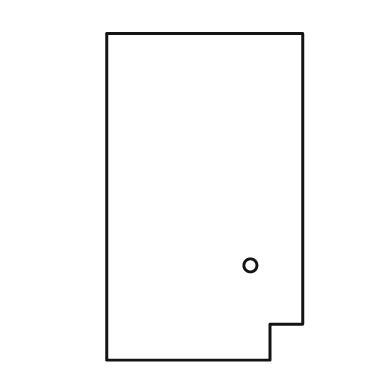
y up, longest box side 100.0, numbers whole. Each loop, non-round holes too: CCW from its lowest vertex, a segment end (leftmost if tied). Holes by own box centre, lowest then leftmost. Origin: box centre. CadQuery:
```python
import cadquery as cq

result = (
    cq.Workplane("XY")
    .moveTo(-30.0, -50.0)
    .lineTo(20.0, -50.0)
    .lineTo(20.0, -39.0)
    .lineTo(30.0, -39.0)
    .lineTo(30.0, 50.0)
    .lineTo(-30.0, 50.0)
    .close()
    .moveTo(14.0, -21.0)
    .circle(2.0)
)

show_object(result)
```